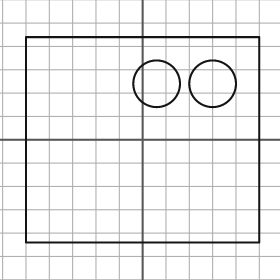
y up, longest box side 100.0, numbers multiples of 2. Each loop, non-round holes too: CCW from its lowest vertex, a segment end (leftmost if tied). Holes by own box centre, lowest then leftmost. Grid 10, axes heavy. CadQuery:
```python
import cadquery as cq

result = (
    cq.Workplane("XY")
    .moveTo(-50.0, -44.0)
    .lineTo(50.0, -44.0)
    .lineTo(50.0, 44.0)
    .lineTo(-50.0, 44.0)
    .close()
    .moveTo(6.0, 24.0)
    .circle(10.0)
    .moveTo(30.0, 24.0)
    .circle(10.0)
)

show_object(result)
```